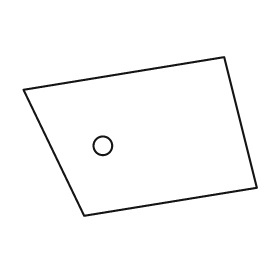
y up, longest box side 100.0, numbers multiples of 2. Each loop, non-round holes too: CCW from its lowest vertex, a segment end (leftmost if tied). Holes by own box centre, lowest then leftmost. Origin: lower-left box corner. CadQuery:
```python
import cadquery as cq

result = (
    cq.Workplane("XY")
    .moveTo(26.0, 0.0)
    .lineTo(100.0, 12.0)
    .lineTo(86.0, 68.0)
    .lineTo(0.0, 54.0)
    .close()
    .moveTo(34.0, 30.0)
    .circle(4.0)
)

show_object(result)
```